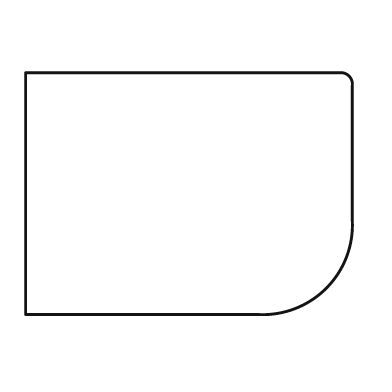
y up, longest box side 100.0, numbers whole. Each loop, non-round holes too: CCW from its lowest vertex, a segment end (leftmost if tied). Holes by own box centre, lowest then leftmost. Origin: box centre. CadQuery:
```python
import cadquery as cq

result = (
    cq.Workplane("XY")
    .moveTo(-50.0, -37.0)
    .lineTo(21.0, -37.0)
    .threePointArc((42.0, -29.0), (50.0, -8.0))
    .lineTo(50.0, 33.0)
    .threePointArc((49.0, 36.0), (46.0, 37.0))
    .lineTo(-50.0, 37.0)
    .close()
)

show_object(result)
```